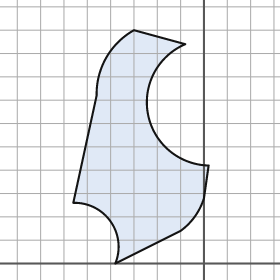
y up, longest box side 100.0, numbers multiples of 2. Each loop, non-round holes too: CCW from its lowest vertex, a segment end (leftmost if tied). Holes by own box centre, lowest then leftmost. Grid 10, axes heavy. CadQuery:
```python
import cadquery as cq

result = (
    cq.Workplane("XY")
    .moveTo(-38.0, 0.0)
    .lineTo(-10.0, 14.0)
    .threePointArc((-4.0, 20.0), (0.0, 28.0))
    .lineTo(2.0, 42.0)
    .threePointArc((-24.0, 64.0), (-8.0, 94.0))
    .lineTo(-30.0, 100.0)
    .threePointArc((-42.0, 88.0), (-46.0, 72.0))
    .lineTo(-56.0, 26.0)
    .threePointArc((-40.0, 18.0), (-38.0, 0.0))
    .close()
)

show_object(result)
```